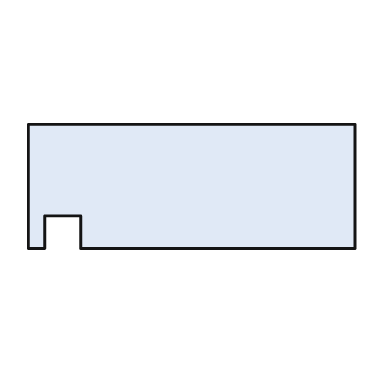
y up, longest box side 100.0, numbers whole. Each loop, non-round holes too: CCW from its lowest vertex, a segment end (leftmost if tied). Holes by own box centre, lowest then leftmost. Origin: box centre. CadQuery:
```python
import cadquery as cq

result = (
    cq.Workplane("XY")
    .moveTo(-50.0, -19.0)
    .lineTo(-45.0, -19.0)
    .lineTo(-45.0, -9.0)
    .lineTo(-34.0, -9.0)
    .lineTo(-34.0, -19.0)
    .lineTo(50.0, -19.0)
    .lineTo(50.0, 19.0)
    .lineTo(-50.0, 19.0)
    .close()
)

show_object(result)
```